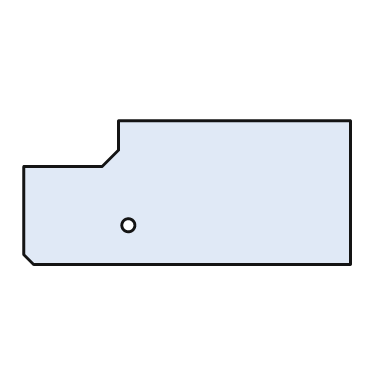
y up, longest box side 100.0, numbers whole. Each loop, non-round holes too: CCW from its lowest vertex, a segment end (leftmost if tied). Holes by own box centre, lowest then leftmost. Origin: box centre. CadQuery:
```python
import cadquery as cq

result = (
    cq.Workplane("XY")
    .moveTo(-47.0, -22.0)
    .lineTo(50.0, -22.0)
    .lineTo(50.0, 22.0)
    .lineTo(-21.0, 22.0)
    .lineTo(-21.0, 13.0)
    .lineTo(-26.0, 8.0)
    .lineTo(-50.0, 8.0)
    .lineTo(-50.0, -19.0)
    .close()
    .moveTo(-18.0, -10.0)
    .circle(2.0)
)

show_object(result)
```